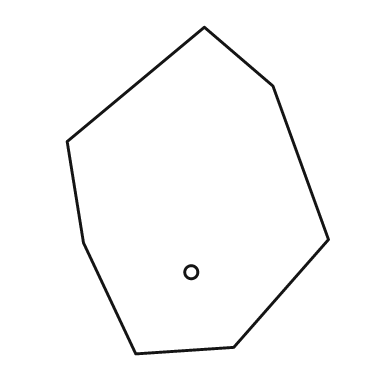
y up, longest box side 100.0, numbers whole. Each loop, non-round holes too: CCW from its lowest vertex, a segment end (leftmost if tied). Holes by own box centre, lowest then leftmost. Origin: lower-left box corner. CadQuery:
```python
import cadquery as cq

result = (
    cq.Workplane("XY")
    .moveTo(21.0, 0.0)
    .lineTo(51.0, 2.0)
    .lineTo(80.0, 35.0)
    .lineTo(63.0, 82.0)
    .lineTo(42.0, 100.0)
    .lineTo(0.0, 65.0)
    .lineTo(5.0, 34.0)
    .close()
    .moveTo(38.0, 25.0)
    .circle(2.0)
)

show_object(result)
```